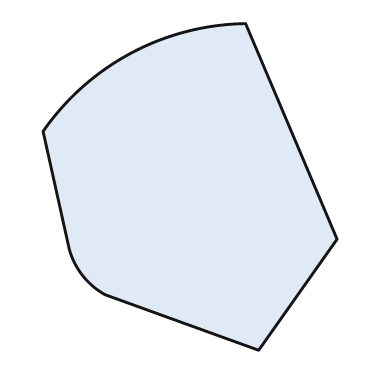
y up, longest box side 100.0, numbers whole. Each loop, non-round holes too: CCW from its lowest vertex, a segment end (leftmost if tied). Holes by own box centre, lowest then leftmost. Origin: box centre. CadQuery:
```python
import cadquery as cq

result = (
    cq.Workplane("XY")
    .moveTo(21.0, -50.0)
    .lineTo(45.0, -16.0)
    .lineTo(17.0, 50.0)
    .threePointArc((-18.0, 41.0), (-45.0, 17.0))
    .lineTo(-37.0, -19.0)
    .threePointArc((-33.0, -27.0), (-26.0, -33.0))
    .close()
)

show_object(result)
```